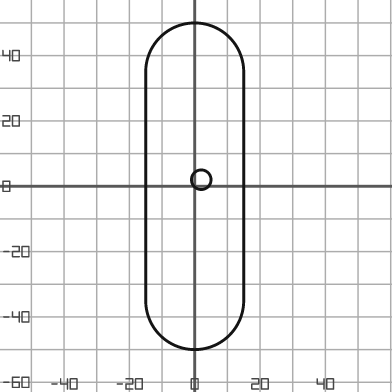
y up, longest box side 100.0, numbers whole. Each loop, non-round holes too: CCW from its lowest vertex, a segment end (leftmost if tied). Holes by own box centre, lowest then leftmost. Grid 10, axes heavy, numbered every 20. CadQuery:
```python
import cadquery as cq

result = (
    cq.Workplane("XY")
    .moveTo(-15.0, -35.0)
    .threePointArc((0.0, -50.0), (15.0, -35.0))
    .lineTo(15.0, 35.0)
    .threePointArc((0.0, 50.0), (-15.0, 35.0))
    .close()
    .moveTo(2.0, 2.0)
    .circle(3.0)
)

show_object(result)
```